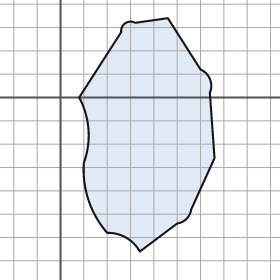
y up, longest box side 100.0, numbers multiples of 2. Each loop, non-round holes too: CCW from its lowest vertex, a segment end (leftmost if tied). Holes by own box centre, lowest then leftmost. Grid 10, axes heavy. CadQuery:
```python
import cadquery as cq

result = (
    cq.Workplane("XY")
    .moveTo(34.0, -66.0)
    .lineTo(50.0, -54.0)
    .threePointArc((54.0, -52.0), (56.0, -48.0))
    .lineTo(66.0, -26.0)
    .lineTo(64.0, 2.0)
    .threePointArc((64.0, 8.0), (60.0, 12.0))
    .lineTo(46.0, 34.0)
    .lineTo(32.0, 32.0)
    .threePointArc((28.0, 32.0), (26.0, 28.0))
    .lineTo(8.0, 0.0)
    .threePointArc((12.0, -14.0), (10.0, -28.0))
    .threePointArc((12.0, -44.0), (20.0, -58.0))
    .threePointArc((28.0, -60.0), (34.0, -66.0))
    .close()
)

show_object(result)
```